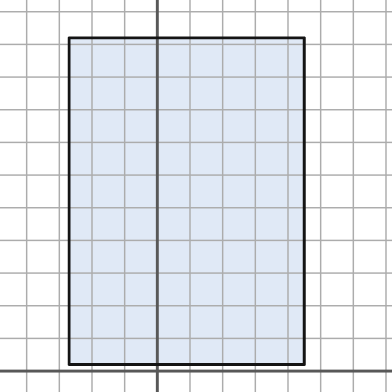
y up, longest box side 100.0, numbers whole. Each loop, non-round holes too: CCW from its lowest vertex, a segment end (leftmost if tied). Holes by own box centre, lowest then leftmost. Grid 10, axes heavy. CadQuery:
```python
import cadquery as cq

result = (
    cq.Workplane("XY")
    .moveTo(-27.0, 2.0)
    .lineTo(45.0, 2.0)
    .lineTo(45.0, 102.0)
    .lineTo(-27.0, 102.0)
    .close()
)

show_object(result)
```